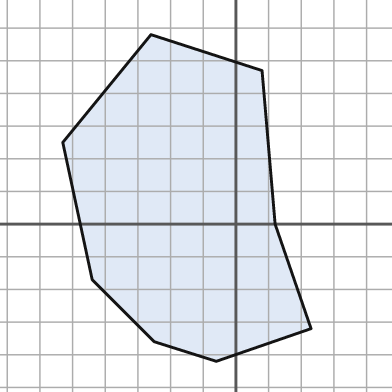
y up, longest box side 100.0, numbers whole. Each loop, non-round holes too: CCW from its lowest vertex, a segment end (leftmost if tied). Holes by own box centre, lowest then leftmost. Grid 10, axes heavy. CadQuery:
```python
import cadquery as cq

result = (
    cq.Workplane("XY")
    .moveTo(-6.0, -42.0)
    .lineTo(23.0, -32.0)
    .lineTo(12.0, 0.0)
    .lineTo(8.0, 47.0)
    .lineTo(-26.0, 58.0)
    .lineTo(-53.0, 25.0)
    .lineTo(-44.0, -17.0)
    .lineTo(-25.0, -36.0)
    .close()
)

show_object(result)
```